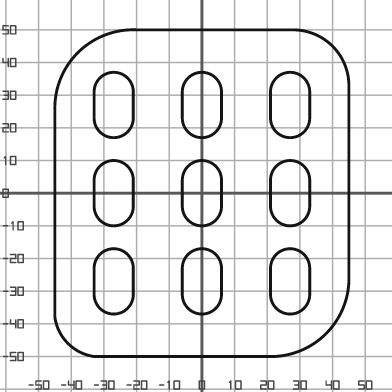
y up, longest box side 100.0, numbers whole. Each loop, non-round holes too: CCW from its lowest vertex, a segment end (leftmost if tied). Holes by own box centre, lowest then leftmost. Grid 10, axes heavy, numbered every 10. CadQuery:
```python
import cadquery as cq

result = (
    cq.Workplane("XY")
    .moveTo(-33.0, -50.0)
    .lineTo(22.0, -50.0)
    .threePointArc((38.0, -43.0), (45.0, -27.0))
    .lineTo(45.0, 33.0)
    .threePointArc((40.0, 45.0), (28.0, 50.0))
    .lineTo(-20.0, 50.0)
    .threePointArc((-38.0, 43.0), (-45.0, 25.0))
    .lineTo(-45.0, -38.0)
    .threePointArc((-41.0, -46.0), (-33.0, -50.0))
    .close()
    .moveTo(-33.0, -31.0)
    .threePointArc((-27.0, -37.0), (-21.0, -31.0))
    .lineTo(-21.0, -23.0)
    .threePointArc((-27.0, -17.0), (-33.0, -23.0))
    .close()
    .moveTo(-6.0, -31.0)
    .threePointArc((0.0, -37.0), (6.0, -31.0))
    .lineTo(6.0, -23.0)
    .threePointArc((0.0, -17.0), (-6.0, -23.0))
    .close()
    .moveTo(21.0, -31.0)
    .threePointArc((27.0, -37.0), (33.0, -31.0))
    .lineTo(33.0, -23.0)
    .threePointArc((27.0, -17.0), (21.0, -23.0))
    .close()
    .moveTo(-33.0, -4.0)
    .threePointArc((-27.0, -10.0), (-21.0, -4.0))
    .lineTo(-21.0, 4.0)
    .threePointArc((-27.0, 10.0), (-33.0, 4.0))
    .close()
    .moveTo(-6.0, -4.0)
    .threePointArc((0.0, -10.0), (6.0, -4.0))
    .lineTo(6.0, 4.0)
    .threePointArc((0.0, 10.0), (-6.0, 4.0))
    .close()
    .moveTo(21.0, -4.0)
    .threePointArc((27.0, -10.0), (33.0, -4.0))
    .lineTo(33.0, 4.0)
    .threePointArc((27.0, 10.0), (21.0, 4.0))
    .close()
    .moveTo(-33.0, 23.0)
    .threePointArc((-27.0, 17.0), (-21.0, 23.0))
    .lineTo(-21.0, 31.0)
    .threePointArc((-27.0, 37.0), (-33.0, 31.0))
    .close()
    .moveTo(-6.0, 23.0)
    .threePointArc((0.0, 17.0), (6.0, 23.0))
    .lineTo(6.0, 31.0)
    .threePointArc((0.0, 37.0), (-6.0, 31.0))
    .close()
    .moveTo(21.0, 23.0)
    .threePointArc((27.0, 17.0), (33.0, 23.0))
    .lineTo(33.0, 31.0)
    .threePointArc((27.0, 37.0), (21.0, 31.0))
    .close()
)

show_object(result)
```